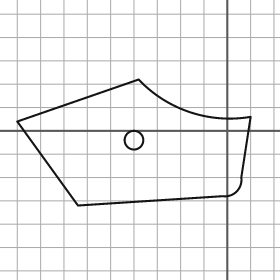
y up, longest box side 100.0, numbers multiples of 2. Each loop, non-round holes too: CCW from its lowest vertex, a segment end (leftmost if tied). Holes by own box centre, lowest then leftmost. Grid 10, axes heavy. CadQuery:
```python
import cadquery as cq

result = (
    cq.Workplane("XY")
    .moveTo(-64.0, -32.0)
    .lineTo(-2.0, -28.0)
    .threePointArc((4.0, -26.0), (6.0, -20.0))
    .lineTo(10.0, 6.0)
    .threePointArc((-16.0, 8.0), (-38.0, 22.0))
    .lineTo(-90.0, 4.0)
    .close()
    .moveTo(-40.0, -4.0)
    .circle(4.0)
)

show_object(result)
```